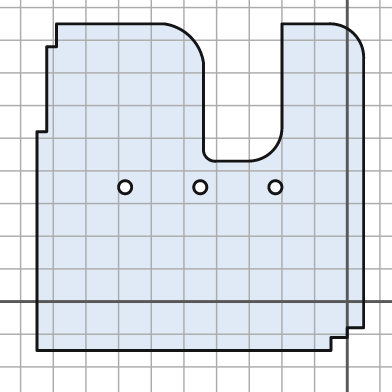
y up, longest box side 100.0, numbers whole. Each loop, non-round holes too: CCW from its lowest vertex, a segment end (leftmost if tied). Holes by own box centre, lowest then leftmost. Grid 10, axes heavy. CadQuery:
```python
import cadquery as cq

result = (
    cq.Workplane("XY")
    .moveTo(-95.0, -15.0)
    .lineTo(-5.0, -15.0)
    .lineTo(-5.0, -11.0)
    .lineTo(0.0, -11.0)
    .lineTo(0.0, -8.0)
    .lineTo(5.0, -8.0)
    .lineTo(5.0, 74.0)
    .threePointArc((2.0, 82.0), (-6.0, 85.0))
    .lineTo(-20.0, 85.0)
    .lineTo(-20.0, 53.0)
    .threePointArc((-23.0, 46.0), (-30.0, 43.0))
    .lineTo(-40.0, 43.0)
    .threePointArc((-43.0, 44.0), (-44.0, 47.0))
    .lineTo(-44.0, 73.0)
    .threePointArc((-48.0, 81.0), (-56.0, 85.0))
    .lineTo(-89.0, 85.0)
    .lineTo(-89.0, 78.0)
    .lineTo(-92.0, 78.0)
    .lineTo(-92.0, 52.0)
    .lineTo(-95.0, 52.0)
    .close()
    .moveTo(-68.0, 35.0)
    .circle(2.0)
    .moveTo(-45.0, 35.0)
    .circle(2.0)
    .moveTo(-22.0, 35.0)
    .circle(2.0)
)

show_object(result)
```